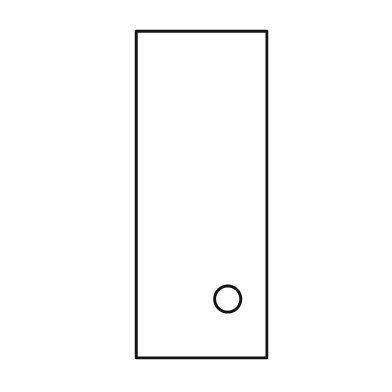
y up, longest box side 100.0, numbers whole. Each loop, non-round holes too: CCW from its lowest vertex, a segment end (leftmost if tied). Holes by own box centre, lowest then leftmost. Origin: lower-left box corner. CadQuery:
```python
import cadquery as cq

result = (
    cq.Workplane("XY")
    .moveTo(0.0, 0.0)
    .lineTo(40.0, 0.0)
    .lineTo(40.0, 100.0)
    .lineTo(0.0, 100.0)
    .close()
    .moveTo(28.0, 18.0)
    .circle(4.0)
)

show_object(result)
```